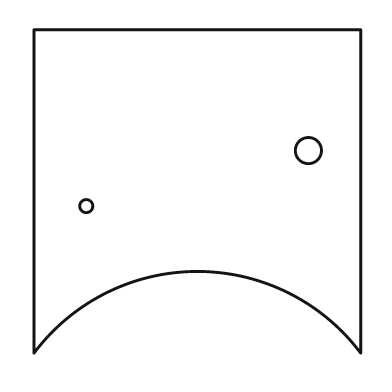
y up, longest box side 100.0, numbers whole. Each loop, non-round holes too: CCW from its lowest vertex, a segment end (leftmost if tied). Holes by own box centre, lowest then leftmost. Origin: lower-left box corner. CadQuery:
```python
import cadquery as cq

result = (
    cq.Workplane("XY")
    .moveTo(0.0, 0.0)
    .threePointArc((50.0, 25.0), (100.0, 0.0))
    .lineTo(100.0, 99.0)
    .lineTo(0.0, 99.0)
    .close()
    .moveTo(16.0, 45.0)
    .circle(2.0)
    .moveTo(84.0, 62.0)
    .circle(4.0)
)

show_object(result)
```